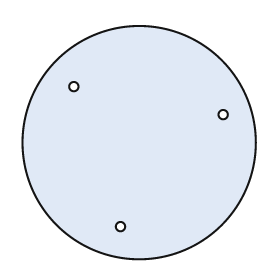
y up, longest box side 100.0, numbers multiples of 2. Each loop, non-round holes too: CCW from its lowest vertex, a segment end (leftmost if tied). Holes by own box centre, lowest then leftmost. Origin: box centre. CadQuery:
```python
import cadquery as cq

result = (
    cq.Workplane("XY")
    .moveTo(0.0, 0.0)
    .circle(50.0)
    .moveTo(-8.0, -36.0)
    .circle(2.0)
    .moveTo(36.0, 12.0)
    .circle(2.0)
    .moveTo(-28.0, 24.0)
    .circle(2.0)
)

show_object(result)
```